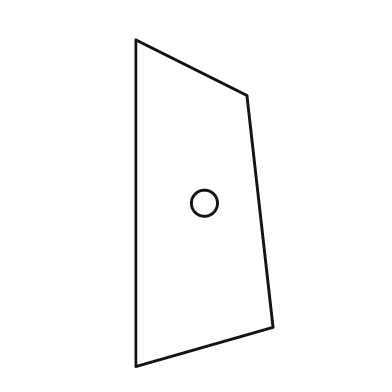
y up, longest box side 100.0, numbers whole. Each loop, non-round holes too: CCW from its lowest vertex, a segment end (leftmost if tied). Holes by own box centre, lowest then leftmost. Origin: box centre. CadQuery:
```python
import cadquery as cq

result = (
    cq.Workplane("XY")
    .moveTo(-21.0, -50.0)
    .lineTo(21.0, -38.0)
    .lineTo(13.0, 33.0)
    .lineTo(-21.0, 50.0)
    .close()
    .moveTo(0.0, 0.0)
    .circle(4.0)
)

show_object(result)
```